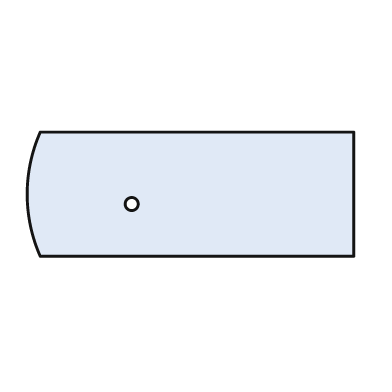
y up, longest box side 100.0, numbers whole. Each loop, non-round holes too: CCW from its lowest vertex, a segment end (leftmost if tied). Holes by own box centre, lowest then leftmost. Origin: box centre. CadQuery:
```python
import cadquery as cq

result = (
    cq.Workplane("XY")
    .moveTo(-46.0, -19.0)
    .lineTo(50.0, -19.0)
    .lineTo(50.0, 19.0)
    .lineTo(-46.0, 19.0)
    .threePointArc((-50.0, 0.0), (-46.0, -19.0))
    .close()
    .moveTo(-18.0, -3.0)
    .circle(2.0)
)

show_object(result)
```